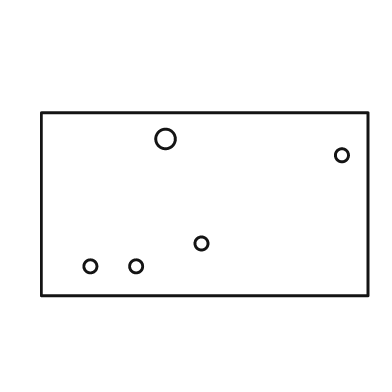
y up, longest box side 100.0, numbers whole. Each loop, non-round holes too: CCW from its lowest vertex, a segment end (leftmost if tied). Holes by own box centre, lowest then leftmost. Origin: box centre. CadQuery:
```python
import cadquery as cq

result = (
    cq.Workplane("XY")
    .moveTo(-50.0, -28.0)
    .lineTo(50.0, -28.0)
    .lineTo(50.0, 28.0)
    .lineTo(-50.0, 28.0)
    .close()
    .moveTo(-35.0, -19.0)
    .circle(2.0)
    .moveTo(-21.0, -19.0)
    .circle(2.0)
    .moveTo(-1.0, -12.0)
    .circle(2.0)
    .moveTo(42.0, 15.0)
    .circle(2.0)
    .moveTo(-12.0, 20.0)
    .circle(3.0)
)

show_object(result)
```